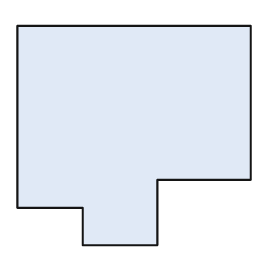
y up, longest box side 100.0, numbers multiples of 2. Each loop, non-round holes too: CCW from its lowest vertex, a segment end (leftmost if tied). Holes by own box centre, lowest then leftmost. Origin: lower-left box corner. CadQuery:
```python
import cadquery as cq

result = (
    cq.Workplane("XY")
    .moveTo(28.0, 0.0)
    .lineTo(60.0, 0.0)
    .lineTo(60.0, 28.0)
    .lineTo(100.0, 28.0)
    .lineTo(100.0, 94.0)
    .lineTo(0.0, 94.0)
    .lineTo(0.0, 16.0)
    .lineTo(28.0, 16.0)
    .close()
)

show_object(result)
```